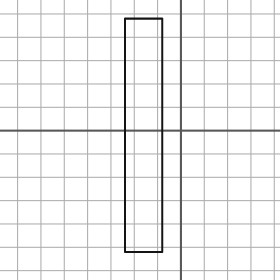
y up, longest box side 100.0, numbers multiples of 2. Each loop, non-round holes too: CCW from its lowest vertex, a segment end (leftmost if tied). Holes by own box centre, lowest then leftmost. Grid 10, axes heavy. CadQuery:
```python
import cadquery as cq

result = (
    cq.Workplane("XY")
    .moveTo(-24.0, -52.0)
    .lineTo(-8.0, -52.0)
    .lineTo(-8.0, 48.0)
    .lineTo(-24.0, 48.0)
    .close()
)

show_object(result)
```